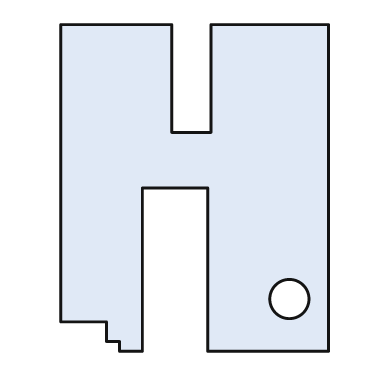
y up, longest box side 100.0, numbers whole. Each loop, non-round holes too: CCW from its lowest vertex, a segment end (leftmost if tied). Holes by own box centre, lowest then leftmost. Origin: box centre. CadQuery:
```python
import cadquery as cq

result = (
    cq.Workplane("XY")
    .moveTo(-23.0, -50.0)
    .lineTo(-16.0, -50.0)
    .lineTo(-16.0, 0.0)
    .lineTo(4.0, 0.0)
    .lineTo(4.0, -50.0)
    .lineTo(41.0, -50.0)
    .lineTo(41.0, 50.0)
    .lineTo(5.0, 50.0)
    .lineTo(5.0, 17.0)
    .lineTo(-7.0, 17.0)
    .lineTo(-7.0, 50.0)
    .lineTo(-41.0, 50.0)
    .lineTo(-41.0, -41.0)
    .lineTo(-27.0, -41.0)
    .lineTo(-27.0, -47.0)
    .lineTo(-23.0, -47.0)
    .close()
    .moveTo(29.0, -34.0)
    .circle(6.0)
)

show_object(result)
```